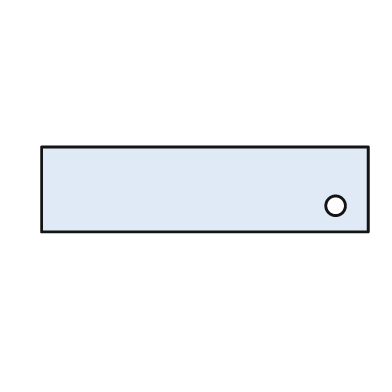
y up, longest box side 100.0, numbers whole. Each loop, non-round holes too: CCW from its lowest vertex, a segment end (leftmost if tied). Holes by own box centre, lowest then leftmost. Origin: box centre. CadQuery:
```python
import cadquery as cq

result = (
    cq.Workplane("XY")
    .moveTo(-50.0, -13.0)
    .lineTo(50.0, -13.0)
    .lineTo(50.0, 13.0)
    .lineTo(-50.0, 13.0)
    .close()
    .moveTo(40.0, -5.0)
    .circle(3.0)
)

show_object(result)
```